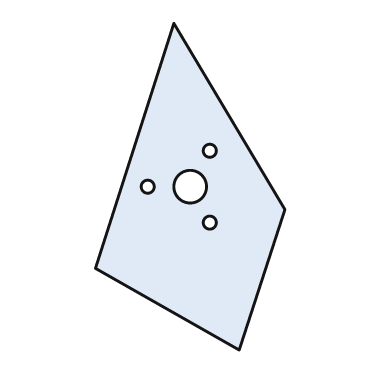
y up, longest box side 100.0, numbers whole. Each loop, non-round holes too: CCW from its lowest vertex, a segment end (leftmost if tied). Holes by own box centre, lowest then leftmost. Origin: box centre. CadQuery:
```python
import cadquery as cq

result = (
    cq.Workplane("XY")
    .moveTo(15.0, -50.0)
    .lineTo(29.0, -7.0)
    .lineTo(-5.0, 50.0)
    .lineTo(-29.0, -25.0)
    .close()
    .moveTo(6.0, -11.0)
    .circle(2.0)
    .moveTo(-13.0, 0.0)
    .circle(2.0)
    .moveTo(0.0, 0.0)
    .circle(5.0)
    .moveTo(6.0, 11.0)
    .circle(2.0)
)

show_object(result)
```